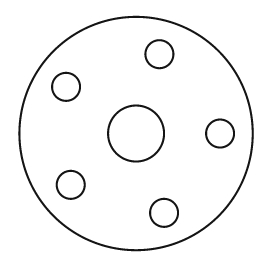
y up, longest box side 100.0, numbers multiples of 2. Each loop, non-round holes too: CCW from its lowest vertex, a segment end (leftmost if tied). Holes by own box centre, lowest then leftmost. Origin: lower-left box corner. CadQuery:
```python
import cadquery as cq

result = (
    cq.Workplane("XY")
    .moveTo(50.0, 50.0)
    .circle(50.0)
    .moveTo(62.0, 16.0)
    .circle(6.0)
    .moveTo(22.0, 28.0)
    .circle(6.0)
    .moveTo(50.0, 50.0)
    .circle(12.0)
    .moveTo(86.0, 50.0)
    .circle(6.0)
    .moveTo(20.0, 70.0)
    .circle(6.0)
    .moveTo(60.0, 84.0)
    .circle(6.0)
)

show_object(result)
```